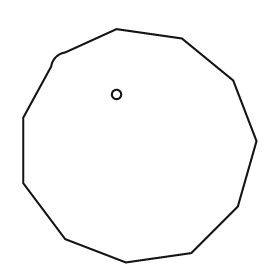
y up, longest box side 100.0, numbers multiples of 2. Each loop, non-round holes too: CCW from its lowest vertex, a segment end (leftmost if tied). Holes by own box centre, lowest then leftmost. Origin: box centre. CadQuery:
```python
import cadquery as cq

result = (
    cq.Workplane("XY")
    .moveTo(-6.0, -50.0)
    .lineTo(22.0, -46.0)
    .lineTo(42.0, -26.0)
    .lineTo(50.0, 2.0)
    .lineTo(40.0, 28.0)
    .lineTo(18.0, 46.0)
    .lineTo(-10.0, 50.0)
    .lineTo(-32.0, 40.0)
    .threePointArc((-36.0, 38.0), (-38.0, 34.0))
    .lineTo(-50.0, 12.0)
    .lineTo(-50.0, -16.0)
    .lineTo(-32.0, -40.0)
    .close()
    .moveTo(-10.0, 22.0)
    .circle(2.0)
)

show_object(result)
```